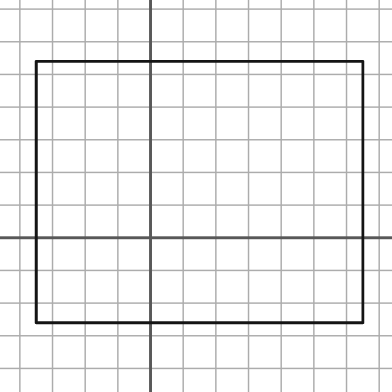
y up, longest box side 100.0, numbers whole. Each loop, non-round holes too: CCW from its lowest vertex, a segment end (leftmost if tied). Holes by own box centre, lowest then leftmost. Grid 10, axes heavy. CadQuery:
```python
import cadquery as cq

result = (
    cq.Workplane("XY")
    .moveTo(-35.0, -26.0)
    .lineTo(65.0, -26.0)
    .lineTo(65.0, 54.0)
    .lineTo(-35.0, 54.0)
    .close()
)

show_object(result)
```